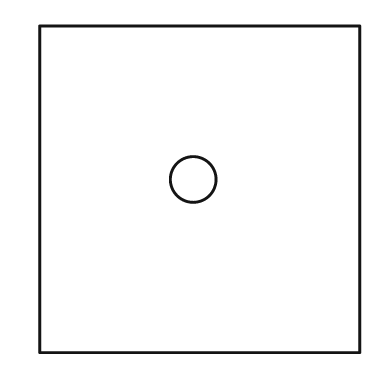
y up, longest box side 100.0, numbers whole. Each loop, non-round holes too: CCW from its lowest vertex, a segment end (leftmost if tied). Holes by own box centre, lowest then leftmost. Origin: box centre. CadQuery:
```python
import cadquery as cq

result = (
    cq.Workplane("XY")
    .moveTo(-49.0, -50.0)
    .lineTo(49.0, -50.0)
    .lineTo(49.0, 50.0)
    .lineTo(-49.0, 50.0)
    .close()
    .moveTo(-2.0, 3.0)
    .circle(7.0)
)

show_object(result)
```